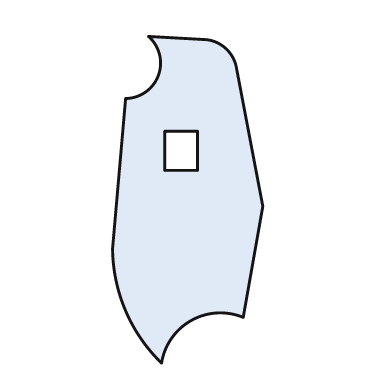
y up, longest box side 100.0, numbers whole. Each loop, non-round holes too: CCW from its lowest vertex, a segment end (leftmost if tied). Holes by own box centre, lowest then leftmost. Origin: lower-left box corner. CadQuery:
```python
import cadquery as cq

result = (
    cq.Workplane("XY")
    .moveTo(15.0, 0.0)
    .threePointArc((24.0, 13.0), (40.0, 14.0))
    .lineTo(46.0, 48.0)
    .lineTo(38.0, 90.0)
    .threePointArc((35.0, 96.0), (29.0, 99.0))
    .lineTo(11.0, 100.0)
    .threePointArc((14.0, 88.0), (4.0, 81.0))
    .lineTo(0.0, 35.0)
    .threePointArc((4.0, 16.0), (15.0, 0.0))
    .close()
    .moveTo(16.0, 59.0)
    .lineTo(26.0, 59.0)
    .lineTo(26.0, 71.0)
    .lineTo(16.0, 71.0)
    .close()
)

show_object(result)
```